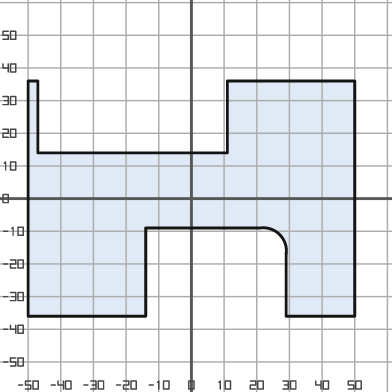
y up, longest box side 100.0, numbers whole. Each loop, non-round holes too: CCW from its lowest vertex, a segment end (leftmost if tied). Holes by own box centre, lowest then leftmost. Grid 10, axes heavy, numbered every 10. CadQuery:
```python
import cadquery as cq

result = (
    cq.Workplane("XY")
    .moveTo(-50.0, -36.0)
    .lineTo(-14.0, -36.0)
    .lineTo(-14.0, -9.0)
    .lineTo(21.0, -9.0)
    .threePointArc((27.0, -11.0), (29.0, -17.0))
    .lineTo(29.0, -36.0)
    .lineTo(50.0, -36.0)
    .lineTo(50.0, 36.0)
    .lineTo(11.0, 36.0)
    .lineTo(11.0, 14.0)
    .lineTo(-47.0, 14.0)
    .lineTo(-47.0, 36.0)
    .lineTo(-50.0, 36.0)
    .close()
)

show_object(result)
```